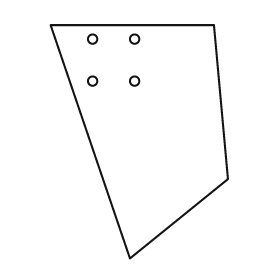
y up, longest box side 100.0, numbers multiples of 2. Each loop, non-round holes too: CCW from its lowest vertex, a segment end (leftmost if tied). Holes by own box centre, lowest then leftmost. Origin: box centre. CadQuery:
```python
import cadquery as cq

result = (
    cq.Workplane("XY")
    .moveTo(-4.0, -50.0)
    .lineTo(38.0, -16.0)
    .lineTo(32.0, 50.0)
    .lineTo(-38.0, 50.0)
    .close()
    .moveTo(-20.0, 26.0)
    .circle(2.0)
    .moveTo(-2.0, 26.0)
    .circle(2.0)
    .moveTo(-20.0, 44.0)
    .circle(2.0)
    .moveTo(-2.0, 44.0)
    .circle(2.0)
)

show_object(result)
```